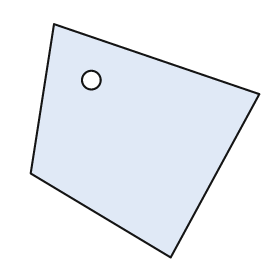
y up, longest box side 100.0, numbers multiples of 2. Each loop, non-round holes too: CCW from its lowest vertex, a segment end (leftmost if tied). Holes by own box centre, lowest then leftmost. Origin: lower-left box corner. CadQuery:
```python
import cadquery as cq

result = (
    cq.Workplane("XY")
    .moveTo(60.0, 0.0)
    .lineTo(98.0, 70.0)
    .lineTo(10.0, 100.0)
    .lineTo(0.0, 36.0)
    .close()
    .moveTo(26.0, 76.0)
    .circle(4.0)
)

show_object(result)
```